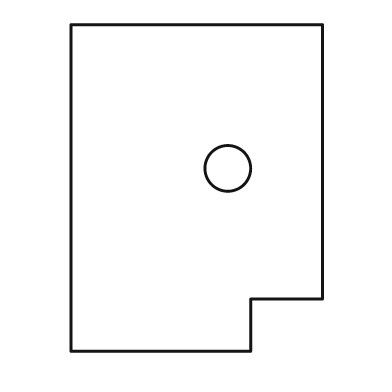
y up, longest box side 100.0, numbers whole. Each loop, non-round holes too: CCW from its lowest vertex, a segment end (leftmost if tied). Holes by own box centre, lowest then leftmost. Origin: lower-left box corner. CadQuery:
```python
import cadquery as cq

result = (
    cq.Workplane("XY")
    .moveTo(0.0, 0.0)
    .lineTo(55.0, 0.0)
    .lineTo(55.0, 16.0)
    .lineTo(77.0, 16.0)
    .lineTo(77.0, 100.0)
    .lineTo(0.0, 100.0)
    .close()
    .moveTo(48.0, 56.0)
    .circle(7.0)
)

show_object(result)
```